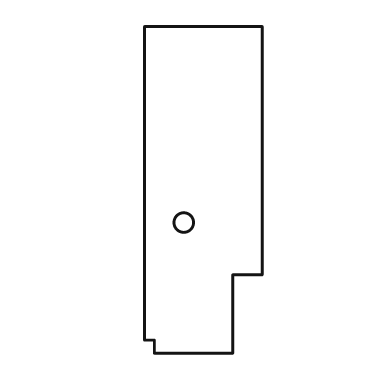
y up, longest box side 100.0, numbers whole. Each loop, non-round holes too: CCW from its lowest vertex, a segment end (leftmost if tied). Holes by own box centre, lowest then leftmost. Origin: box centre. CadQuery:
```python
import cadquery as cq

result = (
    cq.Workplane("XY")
    .moveTo(-15.0, -50.0)
    .lineTo(9.0, -50.0)
    .lineTo(9.0, -26.0)
    .lineTo(18.0, -26.0)
    .lineTo(18.0, 50.0)
    .lineTo(-18.0, 50.0)
    .lineTo(-18.0, -46.0)
    .lineTo(-15.0, -46.0)
    .close()
    .moveTo(-6.0, -10.0)
    .circle(3.0)
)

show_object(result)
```